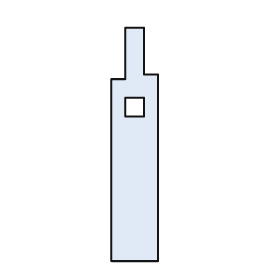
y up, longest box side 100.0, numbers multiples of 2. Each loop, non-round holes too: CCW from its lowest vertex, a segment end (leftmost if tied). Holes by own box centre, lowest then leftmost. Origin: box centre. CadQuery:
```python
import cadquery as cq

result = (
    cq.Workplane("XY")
    .moveTo(-10.0, -50.0)
    .lineTo(10.0, -50.0)
    .lineTo(10.0, 30.0)
    .lineTo(4.0, 30.0)
    .lineTo(4.0, 50.0)
    .lineTo(-4.0, 50.0)
    .lineTo(-4.0, 28.0)
    .lineTo(-10.0, 28.0)
    .close()
    .moveTo(-4.0, 12.0)
    .lineTo(4.0, 12.0)
    .lineTo(4.0, 20.0)
    .lineTo(-4.0, 20.0)
    .close()
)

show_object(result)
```